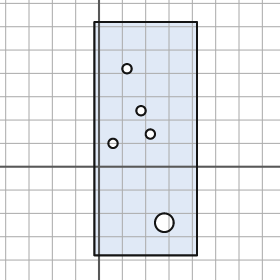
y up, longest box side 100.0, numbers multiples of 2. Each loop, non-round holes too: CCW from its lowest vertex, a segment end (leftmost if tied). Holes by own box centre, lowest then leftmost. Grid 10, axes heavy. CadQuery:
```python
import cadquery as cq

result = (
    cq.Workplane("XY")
    .moveTo(-2.0, -38.0)
    .lineTo(42.0, -38.0)
    .lineTo(42.0, 62.0)
    .lineTo(-2.0, 62.0)
    .close()
    .moveTo(28.0, -24.0)
    .circle(4.0)
    .moveTo(6.0, 10.0)
    .circle(2.0)
    .moveTo(22.0, 14.0)
    .circle(2.0)
    .moveTo(18.0, 24.0)
    .circle(2.0)
    .moveTo(12.0, 42.0)
    .circle(2.0)
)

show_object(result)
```